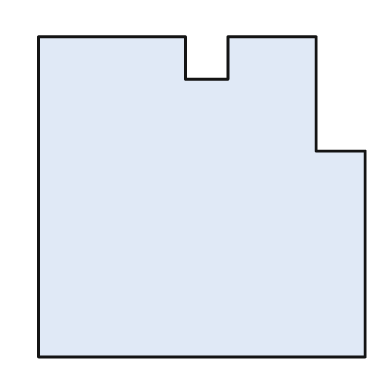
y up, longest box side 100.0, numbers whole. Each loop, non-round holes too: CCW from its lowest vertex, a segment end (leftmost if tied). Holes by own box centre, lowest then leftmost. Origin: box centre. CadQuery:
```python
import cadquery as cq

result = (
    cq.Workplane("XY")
    .moveTo(-50.0, -49.0)
    .lineTo(50.0, -49.0)
    .lineTo(50.0, 14.0)
    .lineTo(35.0, 14.0)
    .lineTo(35.0, 49.0)
    .lineTo(8.0, 49.0)
    .lineTo(8.0, 36.0)
    .lineTo(-5.0, 36.0)
    .lineTo(-5.0, 49.0)
    .lineTo(-50.0, 49.0)
    .close()
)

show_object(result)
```